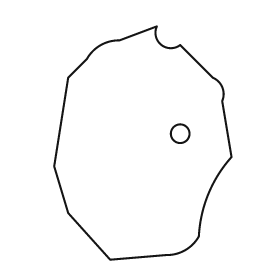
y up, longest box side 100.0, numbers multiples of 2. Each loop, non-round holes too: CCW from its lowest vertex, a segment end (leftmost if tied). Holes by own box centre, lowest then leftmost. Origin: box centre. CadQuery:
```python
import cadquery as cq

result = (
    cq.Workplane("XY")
    .moveTo(-14.0, -50.0)
    .lineTo(10.0, -48.0)
    .threePointArc((18.0, -46.0), (24.0, -40.0))
    .threePointArc((28.0, -22.0), (38.0, -6.0))
    .lineTo(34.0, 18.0)
    .threePointArc((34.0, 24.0), (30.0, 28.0))
    .lineTo(16.0, 42.0)
    .threePointArc((8.0, 42.0), (6.0, 50.0))
    .lineTo(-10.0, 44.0)
    .threePointArc((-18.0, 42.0), (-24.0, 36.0))
    .lineTo(-32.0, 28.0)
    .lineTo(-38.0, -10.0)
    .lineTo(-32.0, -30.0)
    .close()
    .moveTo(16.0, 4.0)
    .circle(4.0)
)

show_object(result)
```